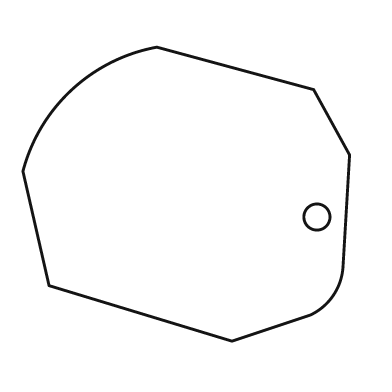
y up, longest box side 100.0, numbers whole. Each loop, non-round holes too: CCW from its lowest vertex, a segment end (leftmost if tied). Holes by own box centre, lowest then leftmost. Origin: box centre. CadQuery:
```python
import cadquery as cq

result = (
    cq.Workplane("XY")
    .moveTo(14.0, -45.0)
    .lineTo(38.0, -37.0)
    .threePointArc((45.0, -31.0), (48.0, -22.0))
    .lineTo(50.0, 12.0)
    .lineTo(39.0, 32.0)
    .lineTo(-9.0, 45.0)
    .threePointArc((-35.0, 32.0), (-50.0, 7.0))
    .lineTo(-42.0, -28.0)
    .close()
    .moveTo(40.0, -7.0)
    .circle(4.0)
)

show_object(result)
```